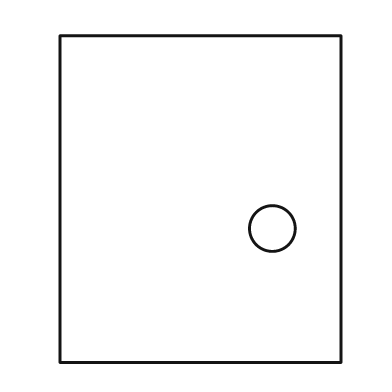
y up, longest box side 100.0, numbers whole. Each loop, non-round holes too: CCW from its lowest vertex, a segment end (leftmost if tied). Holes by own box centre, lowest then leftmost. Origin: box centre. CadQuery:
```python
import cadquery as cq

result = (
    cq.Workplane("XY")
    .moveTo(-43.0, -50.0)
    .lineTo(43.0, -50.0)
    .lineTo(43.0, 50.0)
    .lineTo(-43.0, 50.0)
    .close()
    .moveTo(22.0, -9.0)
    .circle(7.0)
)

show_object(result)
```